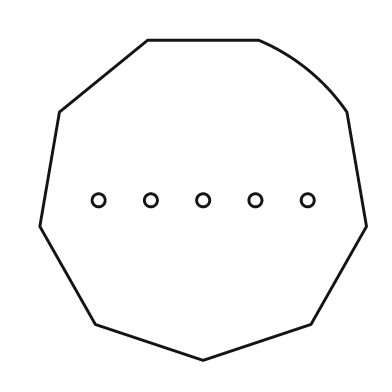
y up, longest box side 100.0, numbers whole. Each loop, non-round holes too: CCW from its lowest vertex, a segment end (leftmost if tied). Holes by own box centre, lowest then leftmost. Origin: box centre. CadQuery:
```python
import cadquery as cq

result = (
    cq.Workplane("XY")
    .moveTo(0.0, -49.0)
    .lineTo(33.0, -38.0)
    .lineTo(50.0, -8.0)
    .lineTo(44.0, 27.0)
    .threePointArc((32.0, 40.0), (17.0, 49.0))
    .lineTo(-17.0, 49.0)
    .lineTo(-44.0, 27.0)
    .lineTo(-50.0, -8.0)
    .lineTo(-33.0, -38.0)
    .close()
    .moveTo(-32.0, 0.0)
    .circle(2.0)
    .moveTo(-16.0, 0.0)
    .circle(2.0)
    .moveTo(0.0, 0.0)
    .circle(2.0)
    .moveTo(16.0, 0.0)
    .circle(2.0)
    .moveTo(32.0, 0.0)
    .circle(2.0)
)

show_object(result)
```